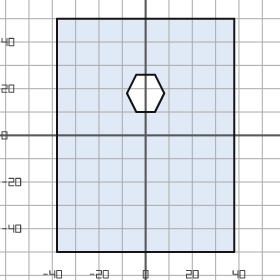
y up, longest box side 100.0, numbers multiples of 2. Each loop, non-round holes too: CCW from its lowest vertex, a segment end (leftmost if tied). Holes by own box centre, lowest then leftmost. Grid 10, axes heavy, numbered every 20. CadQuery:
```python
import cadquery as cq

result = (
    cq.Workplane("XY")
    .moveTo(-38.0, -50.0)
    .lineTo(38.0, -50.0)
    .lineTo(38.0, 50.0)
    .lineTo(-38.0, 50.0)
    .close()
    .moveTo(-4.0, 10.0)
    .lineTo(4.0, 10.0)
    .lineTo(8.0, 18.0)
    .lineTo(4.0, 26.0)
    .lineTo(-4.0, 26.0)
    .lineTo(-8.0, 18.0)
    .close()
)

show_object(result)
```